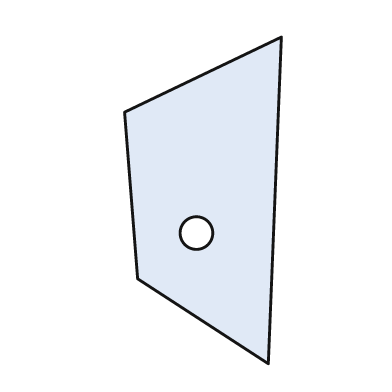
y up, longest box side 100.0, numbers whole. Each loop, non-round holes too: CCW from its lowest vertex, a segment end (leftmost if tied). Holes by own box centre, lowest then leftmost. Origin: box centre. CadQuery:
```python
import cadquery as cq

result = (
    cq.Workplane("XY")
    .moveTo(20.0, -50.0)
    .lineTo(24.0, 50.0)
    .lineTo(-24.0, 27.0)
    .lineTo(-20.0, -24.0)
    .close()
    .moveTo(-2.0, -10.0)
    .circle(5.0)
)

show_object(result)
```